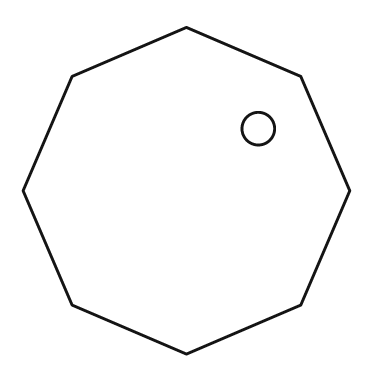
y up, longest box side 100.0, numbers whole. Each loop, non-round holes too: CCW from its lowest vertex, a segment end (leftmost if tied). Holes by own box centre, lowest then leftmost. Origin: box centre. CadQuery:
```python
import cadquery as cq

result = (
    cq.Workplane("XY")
    .moveTo(0.0, -50.0)
    .lineTo(35.0, -35.0)
    .lineTo(50.0, 0.0)
    .lineTo(35.0, 35.0)
    .lineTo(0.0, 50.0)
    .lineTo(-35.0, 35.0)
    .lineTo(-50.0, 0.0)
    .lineTo(-35.0, -35.0)
    .close()
    .moveTo(22.0, 19.0)
    .circle(5.0)
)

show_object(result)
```